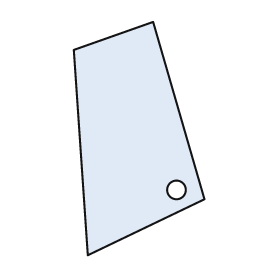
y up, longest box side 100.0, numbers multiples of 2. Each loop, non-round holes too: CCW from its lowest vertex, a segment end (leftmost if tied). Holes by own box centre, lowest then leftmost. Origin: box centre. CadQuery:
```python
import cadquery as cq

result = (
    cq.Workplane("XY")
    .moveTo(-22.0, -50.0)
    .lineTo(28.0, -26.0)
    .lineTo(6.0, 50.0)
    .lineTo(-28.0, 38.0)
    .close()
    .moveTo(16.0, -22.0)
    .circle(4.0)
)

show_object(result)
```